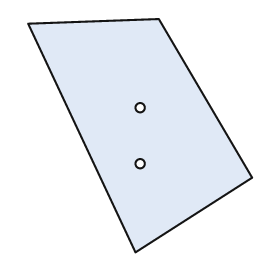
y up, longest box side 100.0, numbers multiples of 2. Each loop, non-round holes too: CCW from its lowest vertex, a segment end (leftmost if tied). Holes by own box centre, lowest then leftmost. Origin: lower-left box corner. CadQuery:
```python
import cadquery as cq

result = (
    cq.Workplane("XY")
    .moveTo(46.0, 0.0)
    .lineTo(96.0, 32.0)
    .lineTo(56.0, 100.0)
    .lineTo(0.0, 98.0)
    .close()
    .moveTo(48.0, 38.0)
    .circle(2.0)
    .moveTo(48.0, 62.0)
    .circle(2.0)
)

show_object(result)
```